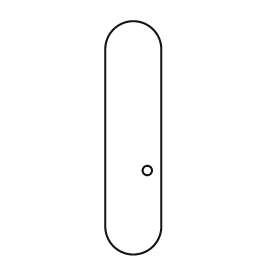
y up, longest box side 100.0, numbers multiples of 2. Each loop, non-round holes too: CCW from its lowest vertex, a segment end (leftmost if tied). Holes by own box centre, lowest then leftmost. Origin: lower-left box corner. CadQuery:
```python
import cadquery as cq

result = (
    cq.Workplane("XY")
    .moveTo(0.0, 12.0)
    .threePointArc((12.0, 0.0), (24.0, 12.0))
    .lineTo(24.0, 88.0)
    .threePointArc((12.0, 100.0), (0.0, 88.0))
    .close()
    .moveTo(18.0, 36.0)
    .circle(2.0)
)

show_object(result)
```